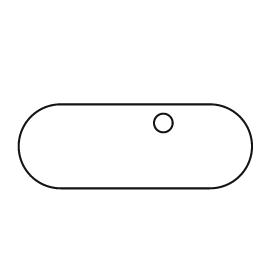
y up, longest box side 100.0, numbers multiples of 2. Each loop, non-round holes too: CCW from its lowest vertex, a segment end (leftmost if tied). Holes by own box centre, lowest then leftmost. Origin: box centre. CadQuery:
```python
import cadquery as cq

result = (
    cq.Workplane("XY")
    .moveTo(-32.0, -18.0)
    .lineTo(32.0, -18.0)
    .threePointArc((50.0, 0.0), (32.0, 18.0))
    .lineTo(-32.0, 18.0)
    .threePointArc((-50.0, 0.0), (-32.0, -18.0))
    .close()
    .moveTo(12.0, 10.0)
    .circle(4.0)
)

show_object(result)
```